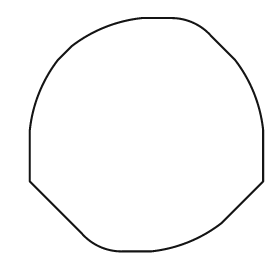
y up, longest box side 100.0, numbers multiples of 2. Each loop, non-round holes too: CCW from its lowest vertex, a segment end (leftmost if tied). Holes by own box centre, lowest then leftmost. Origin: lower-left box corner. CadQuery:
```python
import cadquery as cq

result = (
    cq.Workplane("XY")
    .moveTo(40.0, 0.0)
    .lineTo(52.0, 0.0)
    .threePointArc((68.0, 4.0), (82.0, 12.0))
    .lineTo(100.0, 30.0)
    .lineTo(100.0, 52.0)
    .threePointArc((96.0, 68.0), (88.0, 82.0))
    .lineTo(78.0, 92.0)
    .threePointArc((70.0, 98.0), (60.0, 100.0))
    .lineTo(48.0, 100.0)
    .threePointArc((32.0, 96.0), (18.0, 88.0))
    .lineTo(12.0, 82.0)
    .threePointArc((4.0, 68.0), (0.0, 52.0))
    .lineTo(0.0, 30.0)
    .lineTo(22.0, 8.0)
    .threePointArc((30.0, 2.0), (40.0, 0.0))
    .close()
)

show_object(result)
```